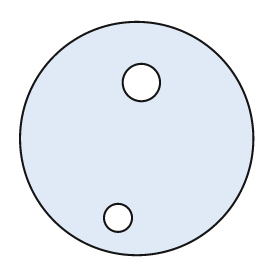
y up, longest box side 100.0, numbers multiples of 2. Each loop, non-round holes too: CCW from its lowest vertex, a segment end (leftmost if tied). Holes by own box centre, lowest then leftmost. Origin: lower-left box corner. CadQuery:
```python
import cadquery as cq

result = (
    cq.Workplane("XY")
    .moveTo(50.0, 50.0)
    .circle(50.0)
    .moveTo(42.0, 16.0)
    .circle(6.0)
    .moveTo(52.0, 74.0)
    .circle(8.0)
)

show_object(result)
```